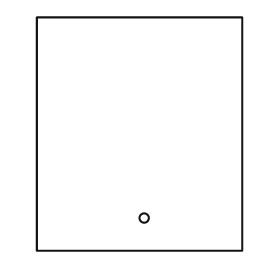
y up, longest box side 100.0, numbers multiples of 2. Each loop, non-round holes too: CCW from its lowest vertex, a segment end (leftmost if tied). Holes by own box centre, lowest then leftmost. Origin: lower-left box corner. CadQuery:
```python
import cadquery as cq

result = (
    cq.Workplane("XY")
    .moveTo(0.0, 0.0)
    .lineTo(88.0, 0.0)
    .lineTo(88.0, 100.0)
    .lineTo(0.0, 100.0)
    .close()
    .moveTo(46.0, 14.0)
    .circle(2.0)
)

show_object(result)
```